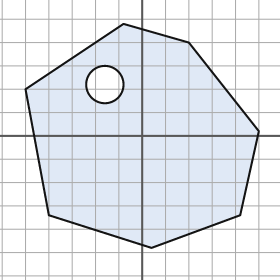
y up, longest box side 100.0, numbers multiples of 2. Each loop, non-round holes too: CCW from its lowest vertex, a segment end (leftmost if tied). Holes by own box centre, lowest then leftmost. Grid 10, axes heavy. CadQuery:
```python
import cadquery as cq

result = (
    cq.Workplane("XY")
    .moveTo(4.0, -48.0)
    .lineTo(42.0, -34.0)
    .lineTo(50.0, 2.0)
    .lineTo(20.0, 40.0)
    .lineTo(-8.0, 48.0)
    .lineTo(-50.0, 20.0)
    .lineTo(-40.0, -34.0)
    .close()
    .moveTo(-16.0, 22.0)
    .circle(8.0)
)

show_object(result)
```